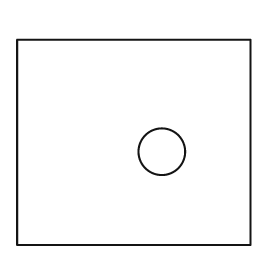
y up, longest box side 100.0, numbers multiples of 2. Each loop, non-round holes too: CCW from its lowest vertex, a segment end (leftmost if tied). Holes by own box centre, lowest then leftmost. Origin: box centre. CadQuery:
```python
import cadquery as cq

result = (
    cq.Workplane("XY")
    .moveTo(-50.0, -44.0)
    .lineTo(50.0, -44.0)
    .lineTo(50.0, 44.0)
    .lineTo(-50.0, 44.0)
    .close()
    .moveTo(12.0, -4.0)
    .circle(10.0)
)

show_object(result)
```